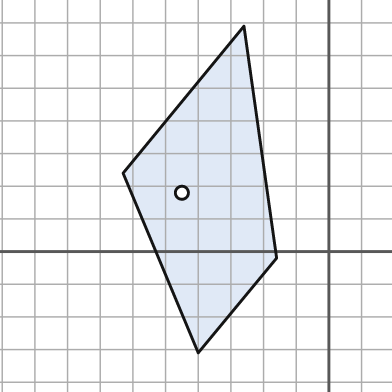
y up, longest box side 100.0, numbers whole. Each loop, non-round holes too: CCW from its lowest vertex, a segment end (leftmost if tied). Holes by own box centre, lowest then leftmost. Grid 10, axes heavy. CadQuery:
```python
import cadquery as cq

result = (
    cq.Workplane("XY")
    .moveTo(-40.0, -31.0)
    .lineTo(-16.0, -2.0)
    .lineTo(-26.0, 69.0)
    .lineTo(-63.0, 24.0)
    .close()
    .moveTo(-45.0, 18.0)
    .circle(2.0)
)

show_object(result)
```